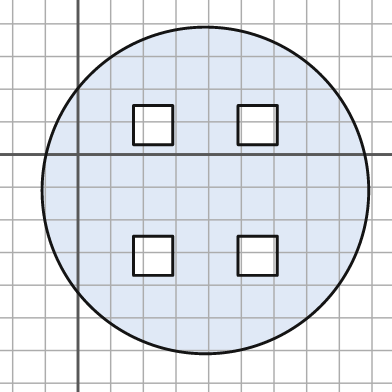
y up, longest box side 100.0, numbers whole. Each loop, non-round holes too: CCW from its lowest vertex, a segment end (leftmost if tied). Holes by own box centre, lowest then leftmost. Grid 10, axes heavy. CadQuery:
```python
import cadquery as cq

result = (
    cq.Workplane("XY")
    .moveTo(39.0, -11.0)
    .circle(50.0)
    .moveTo(17.0, -37.0)
    .lineTo(29.0, -37.0)
    .lineTo(29.0, -25.0)
    .lineTo(17.0, -25.0)
    .close()
    .moveTo(49.0, -37.0)
    .lineTo(61.0, -37.0)
    .lineTo(61.0, -25.0)
    .lineTo(49.0, -25.0)
    .close()
    .moveTo(17.0, 3.0)
    .lineTo(29.0, 3.0)
    .lineTo(29.0, 15.0)
    .lineTo(17.0, 15.0)
    .close()
    .moveTo(49.0, 3.0)
    .lineTo(61.0, 3.0)
    .lineTo(61.0, 15.0)
    .lineTo(49.0, 15.0)
    .close()
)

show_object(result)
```